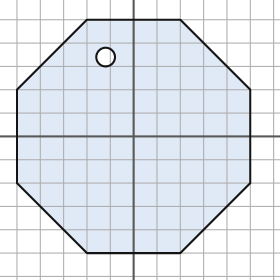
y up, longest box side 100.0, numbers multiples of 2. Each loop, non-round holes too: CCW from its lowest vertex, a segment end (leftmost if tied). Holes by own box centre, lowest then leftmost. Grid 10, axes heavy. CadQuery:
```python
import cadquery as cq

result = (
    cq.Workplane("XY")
    .moveTo(-20.0, -50.0)
    .lineTo(20.0, -50.0)
    .lineTo(50.0, -20.0)
    .lineTo(50.0, 20.0)
    .lineTo(20.0, 50.0)
    .lineTo(-20.0, 50.0)
    .lineTo(-50.0, 20.0)
    .lineTo(-50.0, -20.0)
    .close()
    .moveTo(-12.0, 34.0)
    .circle(4.0)
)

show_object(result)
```